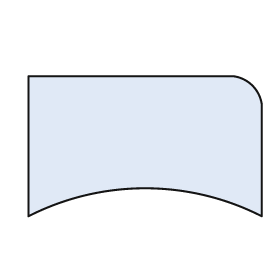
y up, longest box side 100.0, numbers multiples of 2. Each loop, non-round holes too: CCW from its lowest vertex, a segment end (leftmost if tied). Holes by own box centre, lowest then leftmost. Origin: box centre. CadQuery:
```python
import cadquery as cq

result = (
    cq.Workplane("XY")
    .moveTo(-50.0, -30.0)
    .threePointArc((0.0, -18.0), (50.0, -30.0))
    .lineTo(50.0, 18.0)
    .threePointArc((46.0, 26.0), (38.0, 30.0))
    .lineTo(-50.0, 30.0)
    .close()
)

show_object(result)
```